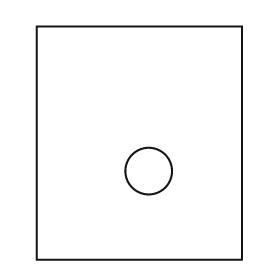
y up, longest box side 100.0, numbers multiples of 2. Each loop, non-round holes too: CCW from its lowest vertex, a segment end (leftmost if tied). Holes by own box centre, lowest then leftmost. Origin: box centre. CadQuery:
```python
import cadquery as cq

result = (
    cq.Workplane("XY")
    .moveTo(-44.0, -50.0)
    .lineTo(44.0, -50.0)
    .lineTo(44.0, 50.0)
    .lineTo(-44.0, 50.0)
    .close()
    .moveTo(4.0, -12.0)
    .circle(10.0)
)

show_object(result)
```